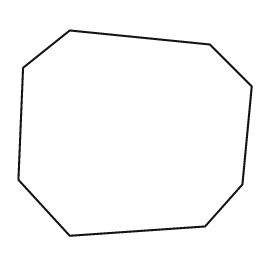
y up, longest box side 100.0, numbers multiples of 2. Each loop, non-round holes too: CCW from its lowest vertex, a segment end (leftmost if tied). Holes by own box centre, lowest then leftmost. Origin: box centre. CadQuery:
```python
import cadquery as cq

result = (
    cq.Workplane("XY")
    .moveTo(-28.0, -44.0)
    .lineTo(30.0, -40.0)
    .lineTo(46.0, -22.0)
    .lineTo(50.0, 20.0)
    .lineTo(32.0, 38.0)
    .lineTo(-28.0, 44.0)
    .lineTo(-48.0, 28.0)
    .lineTo(-50.0, -20.0)
    .close()
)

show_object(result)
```